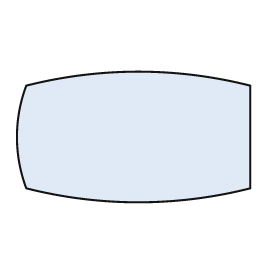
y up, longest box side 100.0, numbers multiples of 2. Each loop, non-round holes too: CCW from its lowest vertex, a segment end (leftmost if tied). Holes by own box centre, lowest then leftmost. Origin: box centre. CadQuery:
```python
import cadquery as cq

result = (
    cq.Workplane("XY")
    .moveTo(-46.0, -22.0)
    .threePointArc((2.0, -28.0), (50.0, -22.0))
    .lineTo(50.0, 22.0)
    .threePointArc((2.0, 28.0), (-46.0, 22.0))
    .threePointArc((-50.0, 0.0), (-46.0, -22.0))
    .close()
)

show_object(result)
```